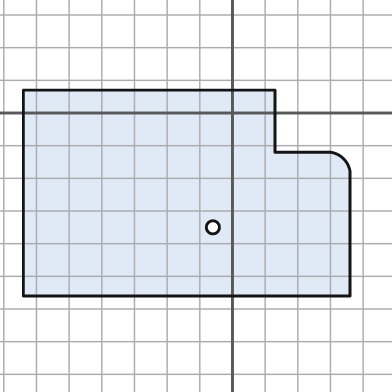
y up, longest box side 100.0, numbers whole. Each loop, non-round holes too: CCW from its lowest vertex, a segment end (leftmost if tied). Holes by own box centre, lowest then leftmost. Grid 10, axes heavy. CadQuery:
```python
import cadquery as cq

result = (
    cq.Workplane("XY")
    .moveTo(-64.0, -56.0)
    .lineTo(36.0, -56.0)
    .lineTo(36.0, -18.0)
    .threePointArc((34.0, -14.0), (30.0, -12.0))
    .lineTo(13.0, -12.0)
    .lineTo(13.0, 7.0)
    .lineTo(-64.0, 7.0)
    .close()
    .moveTo(-6.0, -35.0)
    .circle(2.0)
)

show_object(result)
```